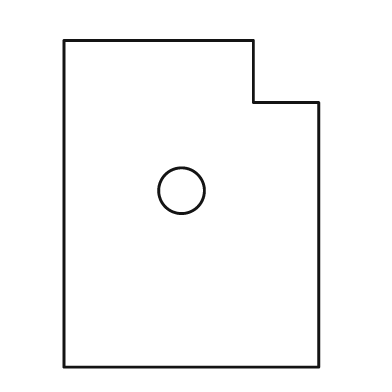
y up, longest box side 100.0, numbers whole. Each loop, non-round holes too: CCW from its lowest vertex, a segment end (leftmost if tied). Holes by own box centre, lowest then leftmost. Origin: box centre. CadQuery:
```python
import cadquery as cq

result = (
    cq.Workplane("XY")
    .moveTo(-39.0, -50.0)
    .lineTo(39.0, -50.0)
    .lineTo(39.0, 31.0)
    .lineTo(19.0, 31.0)
    .lineTo(19.0, 50.0)
    .lineTo(-39.0, 50.0)
    .close()
    .moveTo(-3.0, 4.0)
    .circle(7.0)
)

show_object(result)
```